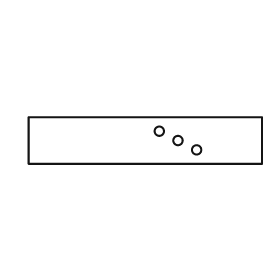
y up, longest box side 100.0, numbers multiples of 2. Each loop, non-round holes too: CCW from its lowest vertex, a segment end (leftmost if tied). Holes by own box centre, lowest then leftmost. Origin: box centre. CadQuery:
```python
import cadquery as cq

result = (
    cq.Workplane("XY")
    .moveTo(-50.0, -10.0)
    .lineTo(50.0, -10.0)
    .lineTo(50.0, 10.0)
    .lineTo(-50.0, 10.0)
    .close()
    .moveTo(22.0, -4.0)
    .circle(2.0)
    .moveTo(14.0, 0.0)
    .circle(2.0)
    .moveTo(6.0, 4.0)
    .circle(2.0)
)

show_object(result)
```